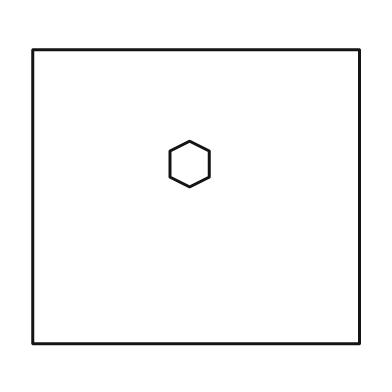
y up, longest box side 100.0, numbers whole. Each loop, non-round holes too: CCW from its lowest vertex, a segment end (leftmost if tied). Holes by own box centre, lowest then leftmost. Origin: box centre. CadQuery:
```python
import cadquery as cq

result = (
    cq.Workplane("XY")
    .moveTo(-50.0, -45.0)
    .lineTo(50.0, -45.0)
    .lineTo(50.0, 45.0)
    .lineTo(-50.0, 45.0)
    .close()
    .moveTo(-2.0, 3.0)
    .lineTo(4.0, 6.0)
    .lineTo(4.0, 14.0)
    .lineTo(-2.0, 17.0)
    .lineTo(-8.0, 14.0)
    .lineTo(-8.0, 6.0)
    .close()
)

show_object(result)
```